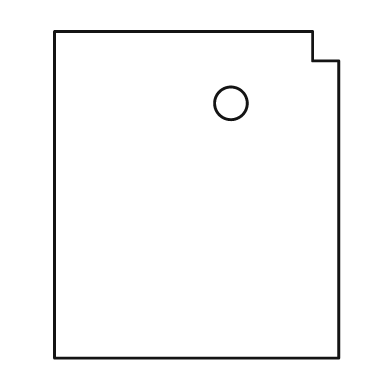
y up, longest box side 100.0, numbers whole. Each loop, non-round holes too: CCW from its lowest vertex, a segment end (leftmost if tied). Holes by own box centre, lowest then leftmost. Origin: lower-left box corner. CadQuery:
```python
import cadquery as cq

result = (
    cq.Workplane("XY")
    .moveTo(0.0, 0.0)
    .lineTo(87.0, 0.0)
    .lineTo(87.0, 91.0)
    .lineTo(79.0, 91.0)
    .lineTo(79.0, 100.0)
    .lineTo(0.0, 100.0)
    .close()
    .moveTo(54.0, 78.0)
    .circle(5.0)
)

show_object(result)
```